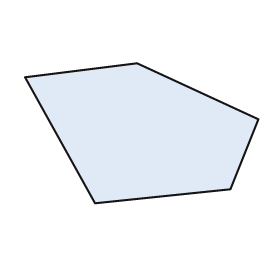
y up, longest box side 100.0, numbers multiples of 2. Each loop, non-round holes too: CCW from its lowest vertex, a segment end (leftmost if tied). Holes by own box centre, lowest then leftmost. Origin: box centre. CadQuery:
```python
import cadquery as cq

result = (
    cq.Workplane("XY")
    .moveTo(-20.0, -30.0)
    .lineTo(38.0, -24.0)
    .lineTo(50.0, 6.0)
    .lineTo(-2.0, 30.0)
    .lineTo(-50.0, 24.0)
    .close()
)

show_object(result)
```